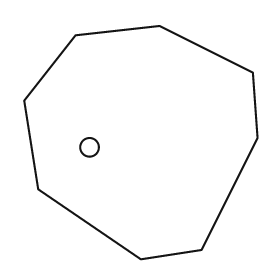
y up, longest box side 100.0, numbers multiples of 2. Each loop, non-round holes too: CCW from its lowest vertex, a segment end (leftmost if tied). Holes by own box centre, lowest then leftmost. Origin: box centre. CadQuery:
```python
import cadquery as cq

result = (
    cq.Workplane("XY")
    .moveTo(0.0, -50.0)
    .lineTo(26.0, -46.0)
    .lineTo(50.0, 2.0)
    .lineTo(48.0, 30.0)
    .lineTo(8.0, 50.0)
    .lineTo(-28.0, 46.0)
    .lineTo(-50.0, 18.0)
    .lineTo(-44.0, -20.0)
    .close()
    .moveTo(-22.0, -2.0)
    .circle(4.0)
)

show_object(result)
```